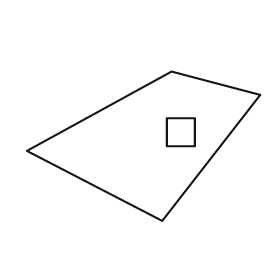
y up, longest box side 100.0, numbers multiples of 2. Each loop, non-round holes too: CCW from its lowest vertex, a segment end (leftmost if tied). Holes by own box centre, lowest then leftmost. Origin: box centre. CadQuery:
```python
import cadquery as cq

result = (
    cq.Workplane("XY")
    .moveTo(8.0, -32.0)
    .lineTo(50.0, 22.0)
    .lineTo(12.0, 32.0)
    .lineTo(-50.0, -2.0)
    .close()
    .moveTo(10.0, 0.0)
    .lineTo(22.0, 0.0)
    .lineTo(22.0, 12.0)
    .lineTo(10.0, 12.0)
    .close()
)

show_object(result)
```